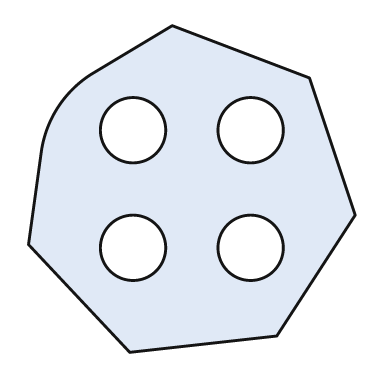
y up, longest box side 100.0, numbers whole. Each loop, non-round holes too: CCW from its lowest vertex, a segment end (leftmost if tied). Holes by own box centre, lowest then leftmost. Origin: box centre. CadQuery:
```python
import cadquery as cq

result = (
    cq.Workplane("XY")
    .moveTo(-19.0, -50.0)
    .lineTo(26.0, -45.0)
    .lineTo(50.0, -8.0)
    .lineTo(36.0, 34.0)
    .lineTo(-6.0, 50.0)
    .lineTo(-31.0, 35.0)
    .threePointArc((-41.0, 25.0), (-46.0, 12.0))
    .lineTo(-50.0, -17.0)
    .close()
    .moveTo(-18.0, -18.0)
    .circle(10.0)
    .moveTo(18.0, -18.0)
    .circle(10.0)
    .moveTo(-18.0, 18.0)
    .circle(10.0)
    .moveTo(18.0, 18.0)
    .circle(10.0)
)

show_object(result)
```